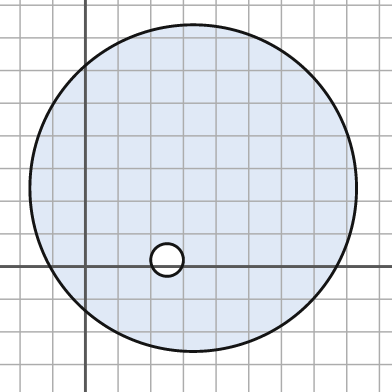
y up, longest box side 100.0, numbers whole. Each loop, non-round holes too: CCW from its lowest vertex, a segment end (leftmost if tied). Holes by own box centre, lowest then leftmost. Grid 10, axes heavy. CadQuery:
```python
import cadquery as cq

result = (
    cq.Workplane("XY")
    .moveTo(33.0, 24.0)
    .circle(50.0)
    .moveTo(25.0, 2.0)
    .circle(5.0)
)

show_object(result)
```